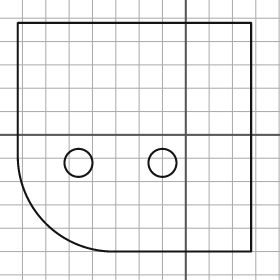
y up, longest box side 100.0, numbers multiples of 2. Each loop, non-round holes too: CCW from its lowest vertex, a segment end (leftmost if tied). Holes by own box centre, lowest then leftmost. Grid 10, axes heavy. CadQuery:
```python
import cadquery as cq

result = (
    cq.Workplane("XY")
    .moveTo(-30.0, -50.0)
    .lineTo(28.0, -50.0)
    .lineTo(28.0, 48.0)
    .lineTo(-72.0, 48.0)
    .lineTo(-72.0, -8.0)
    .threePointArc((-60.0, -38.0), (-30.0, -50.0))
    .close()
    .moveTo(-46.0, -12.0)
    .circle(6.0)
    .moveTo(-10.0, -12.0)
    .circle(6.0)
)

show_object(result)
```